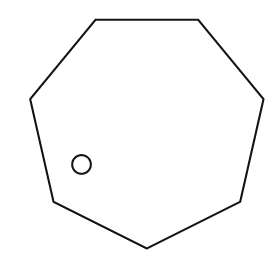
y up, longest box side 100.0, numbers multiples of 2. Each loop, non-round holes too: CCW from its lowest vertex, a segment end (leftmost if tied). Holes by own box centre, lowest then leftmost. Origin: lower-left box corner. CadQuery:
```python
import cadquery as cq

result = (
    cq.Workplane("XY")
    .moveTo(50.0, 0.0)
    .lineTo(90.0, 20.0)
    .lineTo(100.0, 64.0)
    .lineTo(72.0, 98.0)
    .lineTo(28.0, 98.0)
    .lineTo(0.0, 64.0)
    .lineTo(10.0, 20.0)
    .close()
    .moveTo(22.0, 36.0)
    .circle(4.0)
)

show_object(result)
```